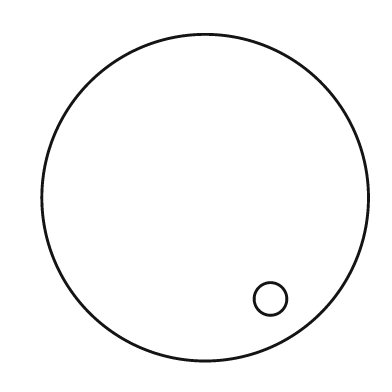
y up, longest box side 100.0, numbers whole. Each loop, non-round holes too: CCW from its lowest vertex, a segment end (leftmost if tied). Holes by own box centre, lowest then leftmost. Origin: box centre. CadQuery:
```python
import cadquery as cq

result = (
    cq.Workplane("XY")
    .moveTo(0.0, 0.0)
    .circle(50.0)
    .moveTo(20.0, -31.0)
    .circle(5.0)
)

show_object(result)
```